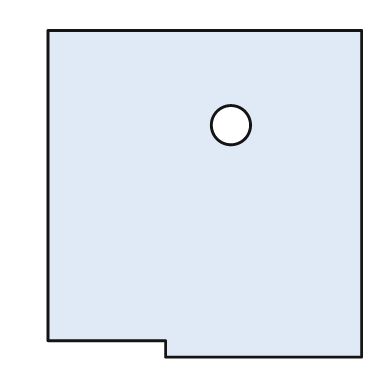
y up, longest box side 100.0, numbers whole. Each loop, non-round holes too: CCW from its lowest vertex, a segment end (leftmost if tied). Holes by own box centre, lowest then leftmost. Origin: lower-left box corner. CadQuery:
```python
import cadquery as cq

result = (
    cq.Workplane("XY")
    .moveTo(36.0, 0.0)
    .lineTo(96.0, 0.0)
    .lineTo(96.0, 100.0)
    .lineTo(0.0, 100.0)
    .lineTo(0.0, 5.0)
    .lineTo(36.0, 5.0)
    .close()
    .moveTo(56.0, 71.0)
    .circle(6.0)
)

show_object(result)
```